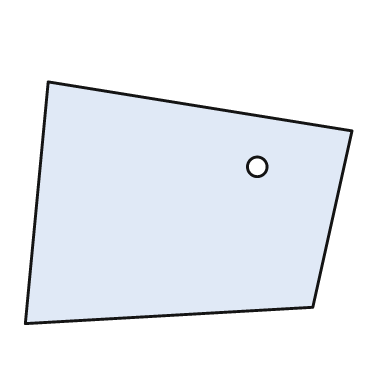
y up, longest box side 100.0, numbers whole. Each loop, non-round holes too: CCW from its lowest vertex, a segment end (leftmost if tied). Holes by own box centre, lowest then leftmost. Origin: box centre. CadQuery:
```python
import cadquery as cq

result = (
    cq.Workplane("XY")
    .moveTo(-50.0, -37.0)
    .lineTo(38.0, -32.0)
    .lineTo(50.0, 22.0)
    .lineTo(-43.0, 37.0)
    .close()
    .moveTo(21.0, 11.0)
    .circle(3.0)
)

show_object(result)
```